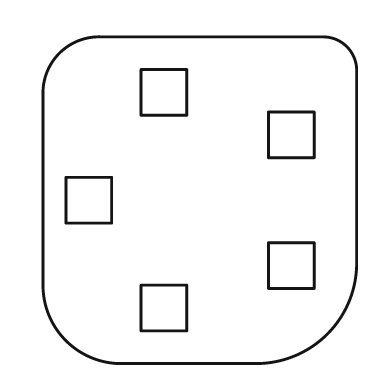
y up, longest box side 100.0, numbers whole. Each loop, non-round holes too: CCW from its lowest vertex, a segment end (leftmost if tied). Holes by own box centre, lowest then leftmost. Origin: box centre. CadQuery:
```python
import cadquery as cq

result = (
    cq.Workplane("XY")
    .moveTo(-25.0, -50.0)
    .lineTo(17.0, -50.0)
    .threePointArc((39.0, -41.0), (48.0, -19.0))
    .lineTo(48.0, 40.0)
    .threePointArc((45.0, 47.0), (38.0, 50.0))
    .lineTo(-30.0, 50.0)
    .threePointArc((-43.0, 45.0), (-48.0, 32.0))
    .lineTo(-48.0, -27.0)
    .threePointArc((-41.0, -43.0), (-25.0, -50.0))
    .close()
    .moveTo(-18.0, -40.0)
    .lineTo(-4.0, -40.0)
    .lineTo(-4.0, -26.0)
    .lineTo(-18.0, -26.0)
    .close()
    .moveTo(21.0, -27.0)
    .lineTo(35.0, -27.0)
    .lineTo(35.0, -13.0)
    .lineTo(21.0, -13.0)
    .close()
    .moveTo(-41.0, -7.0)
    .lineTo(-27.0, -7.0)
    .lineTo(-27.0, 7.0)
    .lineTo(-41.0, 7.0)
    .close()
    .moveTo(21.0, 13.0)
    .lineTo(35.0, 13.0)
    .lineTo(35.0, 27.0)
    .lineTo(21.0, 27.0)
    .close()
    .moveTo(-18.0, 26.0)
    .lineTo(-4.0, 26.0)
    .lineTo(-4.0, 40.0)
    .lineTo(-18.0, 40.0)
    .close()
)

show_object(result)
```